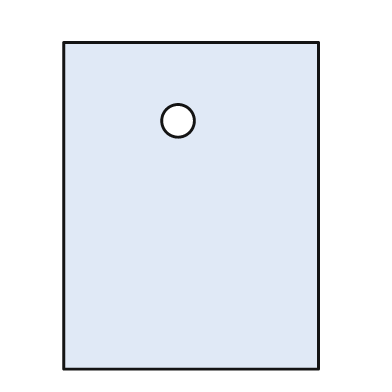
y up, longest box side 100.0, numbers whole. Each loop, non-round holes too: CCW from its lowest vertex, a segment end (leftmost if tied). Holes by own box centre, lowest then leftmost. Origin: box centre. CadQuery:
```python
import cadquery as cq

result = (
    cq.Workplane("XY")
    .moveTo(-39.0, -50.0)
    .lineTo(39.0, -50.0)
    .lineTo(39.0, 50.0)
    .lineTo(-39.0, 50.0)
    .close()
    .moveTo(-4.0, 26.0)
    .circle(5.0)
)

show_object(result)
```